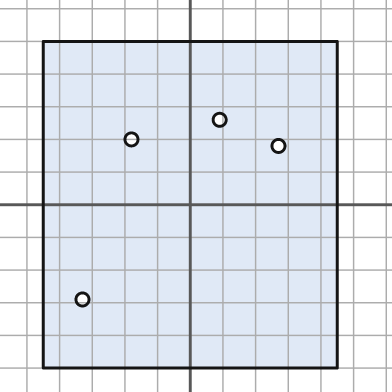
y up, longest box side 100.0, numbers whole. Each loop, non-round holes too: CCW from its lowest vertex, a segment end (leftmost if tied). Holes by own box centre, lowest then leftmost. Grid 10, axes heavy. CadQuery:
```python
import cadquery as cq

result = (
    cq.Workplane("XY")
    .moveTo(-45.0, -50.0)
    .lineTo(45.0, -50.0)
    .lineTo(45.0, 50.0)
    .lineTo(-45.0, 50.0)
    .close()
    .moveTo(-33.0, -29.0)
    .circle(2.0)
    .moveTo(27.0, 18.0)
    .circle(2.0)
    .moveTo(-18.0, 20.0)
    .circle(2.0)
    .moveTo(9.0, 26.0)
    .circle(2.0)
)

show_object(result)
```